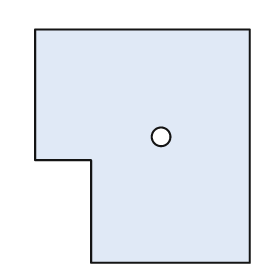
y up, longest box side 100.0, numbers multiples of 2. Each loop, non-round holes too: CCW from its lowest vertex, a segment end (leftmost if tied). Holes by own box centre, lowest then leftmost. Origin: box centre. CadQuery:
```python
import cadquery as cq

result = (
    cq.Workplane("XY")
    .moveTo(-22.0, -50.0)
    .lineTo(46.0, -50.0)
    .lineTo(46.0, 50.0)
    .lineTo(-46.0, 50.0)
    .lineTo(-46.0, -6.0)
    .lineTo(-22.0, -6.0)
    .close()
    .moveTo(8.0, 4.0)
    .circle(4.0)
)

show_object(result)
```